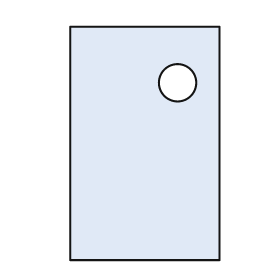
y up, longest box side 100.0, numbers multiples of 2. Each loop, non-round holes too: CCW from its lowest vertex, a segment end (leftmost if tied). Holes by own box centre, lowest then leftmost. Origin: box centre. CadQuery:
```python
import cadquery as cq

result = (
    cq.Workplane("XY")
    .moveTo(-32.0, -50.0)
    .lineTo(32.0, -50.0)
    .lineTo(32.0, 50.0)
    .lineTo(-32.0, 50.0)
    .close()
    .moveTo(14.0, 26.0)
    .circle(8.0)
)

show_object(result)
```